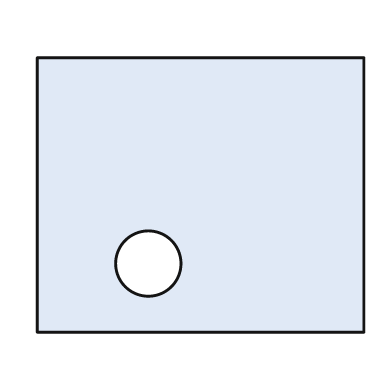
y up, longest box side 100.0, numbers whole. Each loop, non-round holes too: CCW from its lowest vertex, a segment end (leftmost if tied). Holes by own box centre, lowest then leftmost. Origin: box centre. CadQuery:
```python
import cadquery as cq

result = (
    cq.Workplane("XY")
    .moveTo(-50.0, -42.0)
    .lineTo(50.0, -42.0)
    .lineTo(50.0, 42.0)
    .lineTo(-50.0, 42.0)
    .close()
    .moveTo(-16.0, -21.0)
    .circle(10.0)
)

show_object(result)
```